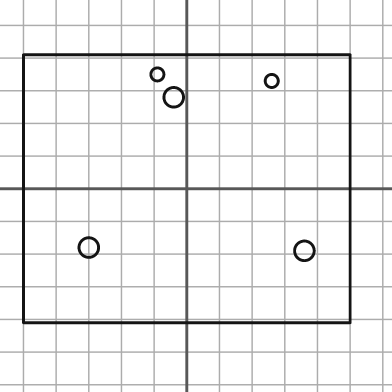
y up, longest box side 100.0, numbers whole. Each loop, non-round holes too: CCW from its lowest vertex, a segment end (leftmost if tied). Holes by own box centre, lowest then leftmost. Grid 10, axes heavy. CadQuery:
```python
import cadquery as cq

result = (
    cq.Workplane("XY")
    .moveTo(-50.0, -41.0)
    .lineTo(50.0, -41.0)
    .lineTo(50.0, 41.0)
    .lineTo(-50.0, 41.0)
    .close()
    .moveTo(36.0, -19.0)
    .circle(3.0)
    .moveTo(-30.0, -18.0)
    .circle(3.0)
    .moveTo(-4.0, 28.0)
    .circle(3.0)
    .moveTo(26.0, 33.0)
    .circle(2.0)
    .moveTo(-9.0, 35.0)
    .circle(2.0)
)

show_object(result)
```